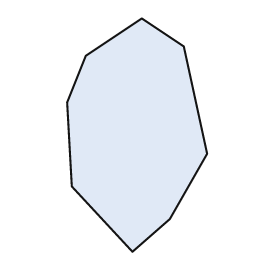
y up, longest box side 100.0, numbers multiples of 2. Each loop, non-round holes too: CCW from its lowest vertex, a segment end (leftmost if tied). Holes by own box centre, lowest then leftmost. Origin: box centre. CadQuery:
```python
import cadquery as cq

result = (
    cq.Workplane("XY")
    .moveTo(-2.0, -50.0)
    .lineTo(14.0, -36.0)
    .lineTo(30.0, -8.0)
    .lineTo(20.0, 38.0)
    .lineTo(2.0, 50.0)
    .lineTo(-22.0, 34.0)
    .lineTo(-30.0, 14.0)
    .lineTo(-28.0, -22.0)
    .close()
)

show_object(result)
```